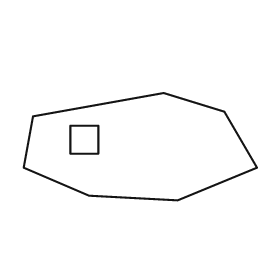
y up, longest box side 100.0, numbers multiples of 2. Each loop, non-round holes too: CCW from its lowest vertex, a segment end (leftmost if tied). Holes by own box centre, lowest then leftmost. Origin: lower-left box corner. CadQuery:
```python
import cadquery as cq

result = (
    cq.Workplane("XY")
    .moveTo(66.0, 0.0)
    .lineTo(100.0, 14.0)
    .lineTo(86.0, 38.0)
    .lineTo(60.0, 46.0)
    .lineTo(4.0, 36.0)
    .lineTo(0.0, 14.0)
    .lineTo(28.0, 2.0)
    .close()
    .moveTo(20.0, 20.0)
    .lineTo(32.0, 20.0)
    .lineTo(32.0, 32.0)
    .lineTo(20.0, 32.0)
    .close()
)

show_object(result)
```